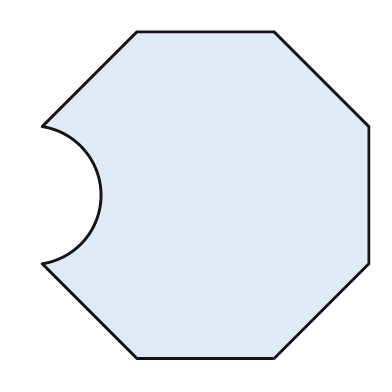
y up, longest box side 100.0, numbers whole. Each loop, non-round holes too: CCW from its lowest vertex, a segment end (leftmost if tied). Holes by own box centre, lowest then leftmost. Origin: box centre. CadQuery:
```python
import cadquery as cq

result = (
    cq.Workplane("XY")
    .moveTo(-21.0, -50.0)
    .lineTo(21.0, -50.0)
    .lineTo(50.0, -21.0)
    .lineTo(50.0, 21.0)
    .lineTo(21.0, 50.0)
    .lineTo(-21.0, 50.0)
    .lineTo(-50.0, 21.0)
    .threePointArc((-32.0, 0.0), (-50.0, -21.0))
    .close()
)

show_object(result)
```